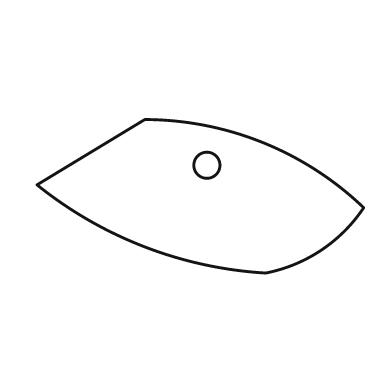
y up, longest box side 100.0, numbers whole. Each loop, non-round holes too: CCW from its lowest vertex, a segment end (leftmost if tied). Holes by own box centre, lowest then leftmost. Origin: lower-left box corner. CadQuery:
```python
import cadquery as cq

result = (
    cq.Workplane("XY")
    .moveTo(70.0, 0.0)
    .threePointArc((87.0, 7.0), (100.0, 20.0))
    .threePointArc((69.0, 40.0), (33.0, 47.0))
    .lineTo(0.0, 27.0)
    .threePointArc((33.0, 8.0), (70.0, 0.0))
    .close()
    .moveTo(52.0, 33.0)
    .circle(4.0)
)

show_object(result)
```